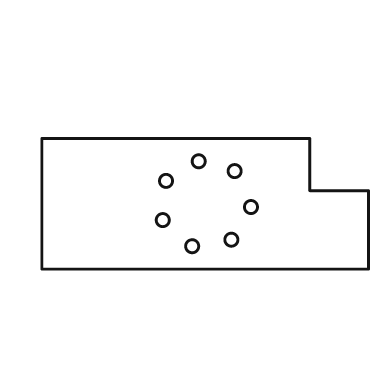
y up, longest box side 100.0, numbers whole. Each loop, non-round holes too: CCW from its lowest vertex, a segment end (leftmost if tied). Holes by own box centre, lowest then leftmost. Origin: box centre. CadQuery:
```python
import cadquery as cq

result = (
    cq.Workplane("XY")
    .moveTo(-50.0, -20.0)
    .lineTo(50.0, -20.0)
    .lineTo(50.0, 4.0)
    .lineTo(32.0, 4.0)
    .lineTo(32.0, 20.0)
    .lineTo(-50.0, 20.0)
    .close()
    .moveTo(-4.0, -13.0)
    .circle(2.0)
    .moveTo(8.0, -11.0)
    .circle(2.0)
    .moveTo(-13.0, -5.0)
    .circle(2.0)
    .moveTo(14.0, -1.0)
    .circle(2.0)
    .moveTo(-12.0, 7.0)
    .circle(2.0)
    .moveTo(9.0, 10.0)
    .circle(2.0)
    .moveTo(-2.0, 13.0)
    .circle(2.0)
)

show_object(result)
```